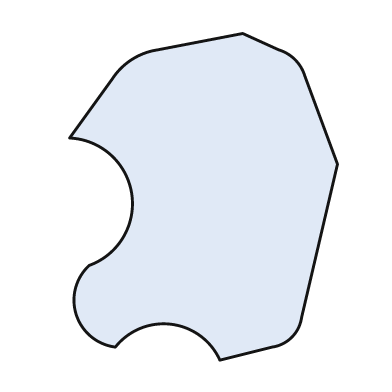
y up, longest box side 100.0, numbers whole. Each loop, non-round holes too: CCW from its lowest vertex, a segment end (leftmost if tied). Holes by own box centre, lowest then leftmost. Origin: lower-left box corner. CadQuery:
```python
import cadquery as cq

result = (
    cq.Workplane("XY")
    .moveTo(46.0, 0.0)
    .lineTo(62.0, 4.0)
    .threePointArc((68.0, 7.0), (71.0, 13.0))
    .lineTo(82.0, 60.0)
    .lineTo(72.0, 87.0)
    .threePointArc((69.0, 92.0), (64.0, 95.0))
    .lineTo(53.0, 100.0)
    .lineTo(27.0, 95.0)
    .threePointArc((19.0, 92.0), (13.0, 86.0))
    .lineTo(0.0, 68.0)
    .threePointArc((19.0, 51.0), (6.0, 29.0))
    .threePointArc((2.0, 14.0), (14.0, 4.0))
    .threePointArc((31.0, 11.0), (46.0, 0.0))
    .close()
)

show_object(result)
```